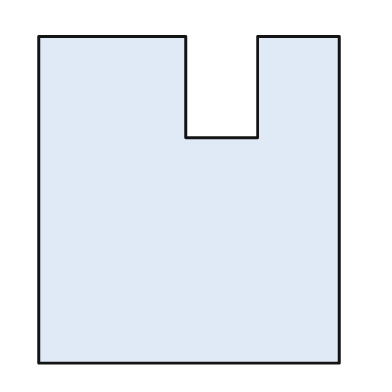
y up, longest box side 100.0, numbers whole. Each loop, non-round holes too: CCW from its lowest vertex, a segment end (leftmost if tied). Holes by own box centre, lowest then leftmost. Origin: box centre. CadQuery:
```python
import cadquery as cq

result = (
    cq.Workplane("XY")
    .moveTo(-46.0, -50.0)
    .lineTo(46.0, -50.0)
    .lineTo(46.0, 50.0)
    .lineTo(21.0, 50.0)
    .lineTo(21.0, 19.0)
    .lineTo(-1.0, 19.0)
    .lineTo(-1.0, 50.0)
    .lineTo(-46.0, 50.0)
    .close()
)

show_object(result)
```